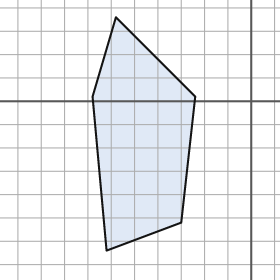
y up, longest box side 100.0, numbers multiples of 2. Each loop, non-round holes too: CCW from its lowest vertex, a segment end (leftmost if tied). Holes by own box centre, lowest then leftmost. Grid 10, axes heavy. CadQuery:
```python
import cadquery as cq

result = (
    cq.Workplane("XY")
    .moveTo(-62.0, -64.0)
    .lineTo(-30.0, -52.0)
    .lineTo(-24.0, 2.0)
    .lineTo(-58.0, 36.0)
    .lineTo(-68.0, 2.0)
    .close()
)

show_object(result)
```